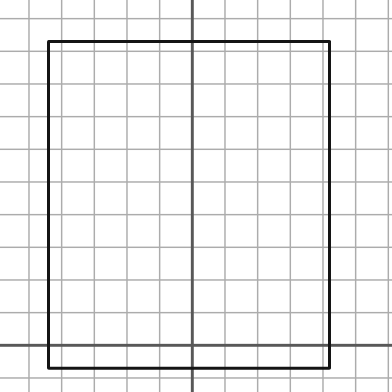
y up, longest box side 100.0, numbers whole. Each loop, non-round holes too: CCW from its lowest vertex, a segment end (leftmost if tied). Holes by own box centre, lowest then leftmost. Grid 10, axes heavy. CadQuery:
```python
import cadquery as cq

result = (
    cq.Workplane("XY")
    .moveTo(-44.0, -7.0)
    .lineTo(42.0, -7.0)
    .lineTo(42.0, 93.0)
    .lineTo(-44.0, 93.0)
    .close()
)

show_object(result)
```